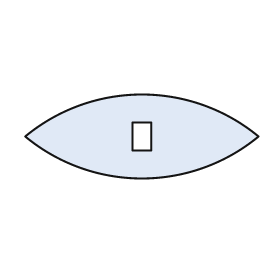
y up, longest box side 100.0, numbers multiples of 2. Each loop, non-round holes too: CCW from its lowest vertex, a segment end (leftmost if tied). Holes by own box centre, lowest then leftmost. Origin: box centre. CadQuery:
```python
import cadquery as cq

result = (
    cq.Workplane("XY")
    .moveTo(-50.0, 0.0)
    .threePointArc((0.0, -18.0), (50.0, 0.0))
    .threePointArc((0.0, 18.0), (-50.0, 0.0))
    .close()
    .moveTo(-4.0, -6.0)
    .lineTo(4.0, -6.0)
    .lineTo(4.0, 6.0)
    .lineTo(-4.0, 6.0)
    .close()
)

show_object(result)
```